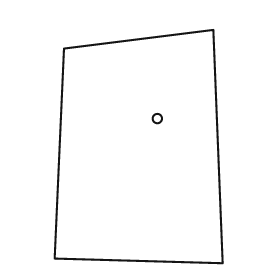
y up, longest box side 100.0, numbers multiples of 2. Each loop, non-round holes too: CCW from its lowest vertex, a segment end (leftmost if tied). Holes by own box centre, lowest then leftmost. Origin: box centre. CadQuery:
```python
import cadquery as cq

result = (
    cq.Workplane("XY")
    .moveTo(36.0, -50.0)
    .lineTo(32.0, 50.0)
    .lineTo(-32.0, 42.0)
    .lineTo(-36.0, -48.0)
    .close()
    .moveTo(8.0, 12.0)
    .circle(2.0)
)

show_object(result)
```